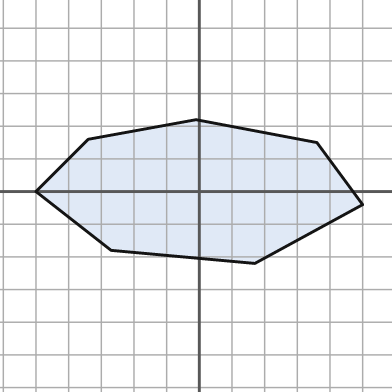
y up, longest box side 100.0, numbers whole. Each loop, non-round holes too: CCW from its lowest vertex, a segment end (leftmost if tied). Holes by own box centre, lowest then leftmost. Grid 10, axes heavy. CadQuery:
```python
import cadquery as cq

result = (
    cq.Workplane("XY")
    .moveTo(17.0, -22.0)
    .lineTo(50.0, -4.0)
    .lineTo(36.0, 15.0)
    .lineTo(-1.0, 22.0)
    .lineTo(-34.0, 16.0)
    .lineTo(-50.0, 0.0)
    .lineTo(-27.0, -18.0)
    .close()
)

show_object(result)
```